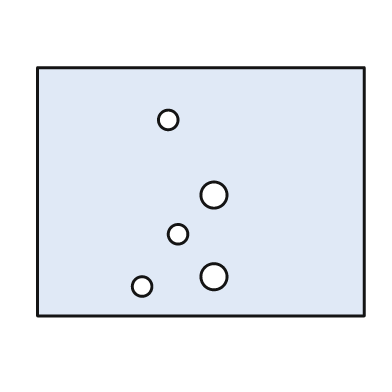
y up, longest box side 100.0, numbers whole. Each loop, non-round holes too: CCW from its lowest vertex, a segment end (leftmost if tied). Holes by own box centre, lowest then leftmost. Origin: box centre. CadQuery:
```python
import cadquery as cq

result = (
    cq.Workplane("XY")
    .moveTo(-50.0, -38.0)
    .lineTo(50.0, -38.0)
    .lineTo(50.0, 38.0)
    .lineTo(-50.0, 38.0)
    .close()
    .moveTo(-18.0, -29.0)
    .circle(3.0)
    .moveTo(4.0, -26.0)
    .circle(4.0)
    .moveTo(-7.0, -13.0)
    .circle(3.0)
    .moveTo(4.0, -1.0)
    .circle(4.0)
    .moveTo(-10.0, 22.0)
    .circle(3.0)
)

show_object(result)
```